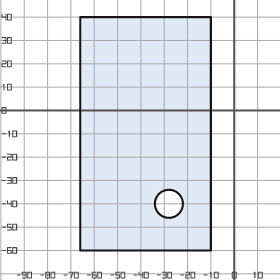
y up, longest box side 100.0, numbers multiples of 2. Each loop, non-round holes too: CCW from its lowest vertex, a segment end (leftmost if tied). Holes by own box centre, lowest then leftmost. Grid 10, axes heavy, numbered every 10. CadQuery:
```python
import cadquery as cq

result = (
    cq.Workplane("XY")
    .moveTo(-66.0, -60.0)
    .lineTo(-10.0, -60.0)
    .lineTo(-10.0, 40.0)
    .lineTo(-66.0, 40.0)
    .close()
    .moveTo(-28.0, -40.0)
    .circle(6.0)
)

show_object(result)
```